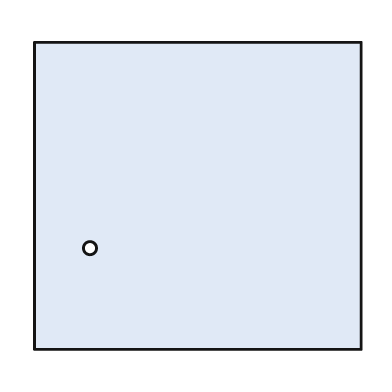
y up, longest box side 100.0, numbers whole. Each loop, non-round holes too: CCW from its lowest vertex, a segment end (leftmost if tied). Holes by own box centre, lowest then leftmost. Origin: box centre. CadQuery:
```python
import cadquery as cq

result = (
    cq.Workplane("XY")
    .moveTo(-50.0, -47.0)
    .lineTo(50.0, -47.0)
    .lineTo(50.0, 47.0)
    .lineTo(-50.0, 47.0)
    .close()
    .moveTo(-33.0, -16.0)
    .circle(2.0)
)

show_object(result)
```